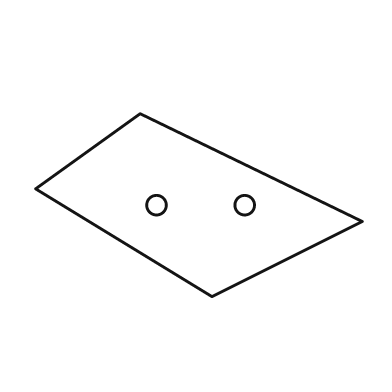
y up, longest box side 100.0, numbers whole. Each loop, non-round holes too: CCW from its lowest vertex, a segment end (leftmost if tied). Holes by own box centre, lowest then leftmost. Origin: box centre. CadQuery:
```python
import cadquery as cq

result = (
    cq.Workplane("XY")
    .moveTo(4.0, -28.0)
    .lineTo(50.0, -5.0)
    .lineTo(-18.0, 28.0)
    .lineTo(-50.0, 5.0)
    .close()
    .moveTo(-13.0, 0.0)
    .circle(3.0)
    .moveTo(14.0, 0.0)
    .circle(3.0)
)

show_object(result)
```